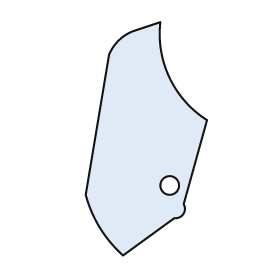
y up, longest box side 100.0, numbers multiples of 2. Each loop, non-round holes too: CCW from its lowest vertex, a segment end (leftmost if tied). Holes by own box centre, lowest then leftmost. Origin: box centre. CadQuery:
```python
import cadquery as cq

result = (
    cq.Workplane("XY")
    .moveTo(-10.0, -50.0)
    .lineTo(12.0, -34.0)
    .threePointArc((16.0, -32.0), (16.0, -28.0))
    .lineTo(26.0, 8.0)
    .threePointArc((10.0, 26.0), (6.0, 50.0))
    .lineTo(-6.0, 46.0)
    .threePointArc((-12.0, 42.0), (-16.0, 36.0))
    .lineTo(-26.0, -24.0)
    .threePointArc((-20.0, -38.0), (-10.0, -50.0))
    .close()
    .moveTo(10.0, -20.0)
    .circle(4.0)
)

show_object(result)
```